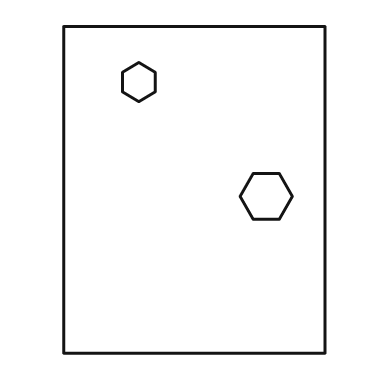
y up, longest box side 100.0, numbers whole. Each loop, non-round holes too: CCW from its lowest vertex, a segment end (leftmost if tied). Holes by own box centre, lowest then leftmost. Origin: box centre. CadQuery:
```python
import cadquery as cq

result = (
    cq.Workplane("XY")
    .moveTo(-40.0, -50.0)
    .lineTo(40.0, -50.0)
    .lineTo(40.0, 50.0)
    .lineTo(-40.0, 50.0)
    .close()
    .moveTo(18.0, -9.0)
    .lineTo(26.0, -9.0)
    .lineTo(30.0, -2.0)
    .lineTo(26.0, 5.0)
    .lineTo(18.0, 5.0)
    .lineTo(14.0, -2.0)
    .close()
    .moveTo(-17.0, 27.0)
    .lineTo(-12.0, 30.0)
    .lineTo(-12.0, 36.0)
    .lineTo(-17.0, 39.0)
    .lineTo(-22.0, 36.0)
    .lineTo(-22.0, 30.0)
    .close()
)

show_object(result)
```